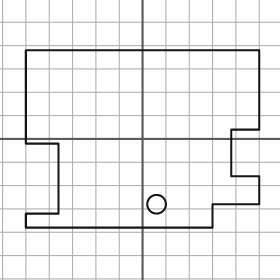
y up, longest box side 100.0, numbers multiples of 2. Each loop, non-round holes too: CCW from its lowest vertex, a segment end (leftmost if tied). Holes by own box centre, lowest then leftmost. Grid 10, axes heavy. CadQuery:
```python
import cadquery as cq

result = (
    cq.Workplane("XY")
    .moveTo(-50.0, -38.0)
    .lineTo(30.0, -38.0)
    .lineTo(30.0, -28.0)
    .lineTo(50.0, -28.0)
    .lineTo(50.0, -16.0)
    .lineTo(38.0, -16.0)
    .lineTo(38.0, 4.0)
    .lineTo(50.0, 4.0)
    .lineTo(50.0, 38.0)
    .lineTo(-50.0, 38.0)
    .lineTo(-50.0, -2.0)
    .lineTo(-36.0, -2.0)
    .lineTo(-36.0, -32.0)
    .lineTo(-50.0, -32.0)
    .close()
    .moveTo(6.0, -28.0)
    .circle(4.0)
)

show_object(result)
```